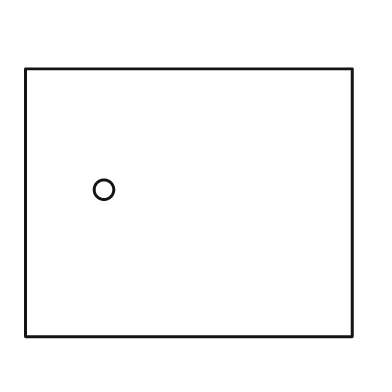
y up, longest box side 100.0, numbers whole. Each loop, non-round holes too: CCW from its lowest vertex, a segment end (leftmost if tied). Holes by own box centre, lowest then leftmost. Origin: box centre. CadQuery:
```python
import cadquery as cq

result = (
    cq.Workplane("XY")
    .moveTo(-50.0, -41.0)
    .lineTo(50.0, -41.0)
    .lineTo(50.0, 41.0)
    .lineTo(-50.0, 41.0)
    .close()
    .moveTo(-26.0, 4.0)
    .circle(3.0)
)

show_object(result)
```